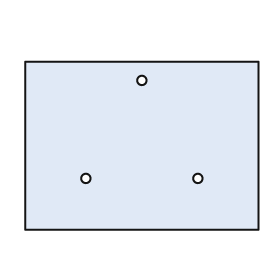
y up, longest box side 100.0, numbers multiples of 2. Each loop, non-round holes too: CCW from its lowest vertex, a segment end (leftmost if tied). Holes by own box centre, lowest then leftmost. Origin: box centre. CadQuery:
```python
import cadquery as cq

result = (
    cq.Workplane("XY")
    .moveTo(-50.0, -36.0)
    .lineTo(50.0, -36.0)
    .lineTo(50.0, 36.0)
    .lineTo(-50.0, 36.0)
    .close()
    .moveTo(-24.0, -14.0)
    .circle(2.0)
    .moveTo(24.0, -14.0)
    .circle(2.0)
    .moveTo(0.0, 28.0)
    .circle(2.0)
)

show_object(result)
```